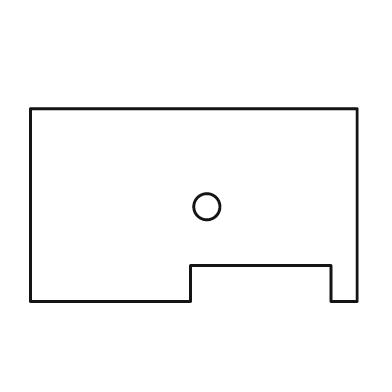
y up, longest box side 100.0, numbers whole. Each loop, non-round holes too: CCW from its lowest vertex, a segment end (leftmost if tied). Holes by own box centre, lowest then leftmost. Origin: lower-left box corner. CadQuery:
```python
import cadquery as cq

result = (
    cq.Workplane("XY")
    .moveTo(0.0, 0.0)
    .lineTo(49.0, 0.0)
    .lineTo(49.0, 11.0)
    .lineTo(92.0, 11.0)
    .lineTo(92.0, 0.0)
    .lineTo(100.0, 0.0)
    .lineTo(100.0, 59.0)
    .lineTo(0.0, 59.0)
    .close()
    .moveTo(54.0, 29.0)
    .circle(4.0)
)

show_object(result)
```